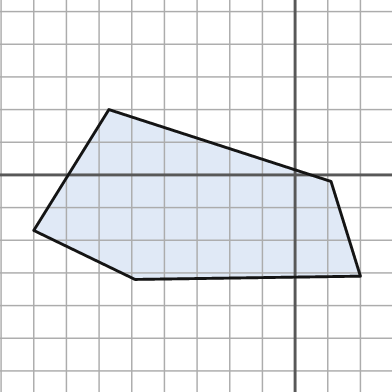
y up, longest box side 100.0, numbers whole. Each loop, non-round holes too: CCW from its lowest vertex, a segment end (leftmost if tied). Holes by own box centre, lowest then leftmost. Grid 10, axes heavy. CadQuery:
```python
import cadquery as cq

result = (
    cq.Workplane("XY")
    .moveTo(-49.0, -32.0)
    .lineTo(20.0, -31.0)
    .lineTo(11.0, -2.0)
    .lineTo(-57.0, 20.0)
    .lineTo(-80.0, -17.0)
    .close()
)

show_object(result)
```